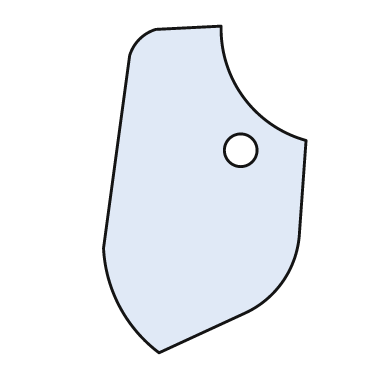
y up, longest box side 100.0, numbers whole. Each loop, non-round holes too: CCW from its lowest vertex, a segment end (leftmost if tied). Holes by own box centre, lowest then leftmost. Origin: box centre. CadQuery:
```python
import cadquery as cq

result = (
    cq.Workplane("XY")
    .moveTo(-14.0, -50.0)
    .lineTo(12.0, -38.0)
    .threePointArc((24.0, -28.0), (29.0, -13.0))
    .lineTo(31.0, 15.0)
    .threePointArc((12.0, 28.0), (5.0, 50.0))
    .lineTo(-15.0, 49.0)
    .threePointArc((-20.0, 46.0), (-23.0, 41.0))
    .lineTo(-31.0, -18.0)
    .threePointArc((-26.0, -36.0), (-14.0, -50.0))
    .close()
    .moveTo(11.0, 12.0)
    .circle(5.0)
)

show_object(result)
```